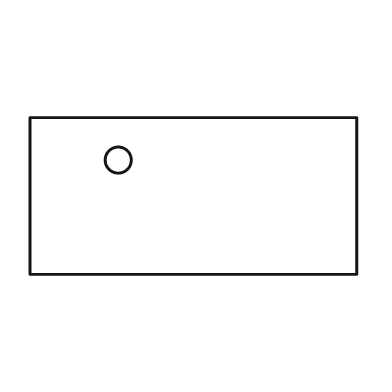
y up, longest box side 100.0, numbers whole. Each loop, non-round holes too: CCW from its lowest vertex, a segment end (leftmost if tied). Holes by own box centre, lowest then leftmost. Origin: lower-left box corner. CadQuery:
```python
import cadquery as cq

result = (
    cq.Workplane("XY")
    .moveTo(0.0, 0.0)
    .lineTo(100.0, 0.0)
    .lineTo(100.0, 48.0)
    .lineTo(0.0, 48.0)
    .close()
    .moveTo(27.0, 35.0)
    .circle(4.0)
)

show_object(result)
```